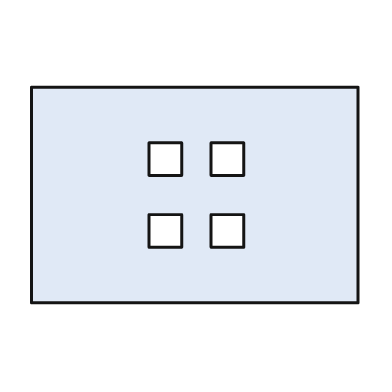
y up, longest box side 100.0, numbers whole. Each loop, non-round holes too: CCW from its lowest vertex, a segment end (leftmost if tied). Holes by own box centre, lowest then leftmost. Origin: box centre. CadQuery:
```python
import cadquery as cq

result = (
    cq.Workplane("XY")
    .moveTo(-50.0, -33.0)
    .lineTo(50.0, -33.0)
    .lineTo(50.0, 33.0)
    .lineTo(-50.0, 33.0)
    .close()
    .moveTo(-14.0, -16.0)
    .lineTo(-4.0, -16.0)
    .lineTo(-4.0, -6.0)
    .lineTo(-14.0, -6.0)
    .close()
    .moveTo(5.0, -16.0)
    .lineTo(15.0, -16.0)
    .lineTo(15.0, -6.0)
    .lineTo(5.0, -6.0)
    .close()
    .moveTo(-14.0, 6.0)
    .lineTo(-4.0, 6.0)
    .lineTo(-4.0, 16.0)
    .lineTo(-14.0, 16.0)
    .close()
    .moveTo(5.0, 6.0)
    .lineTo(15.0, 6.0)
    .lineTo(15.0, 16.0)
    .lineTo(5.0, 16.0)
    .close()
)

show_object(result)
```